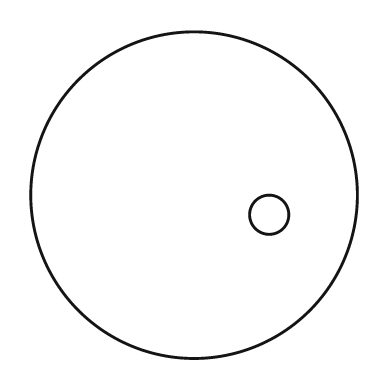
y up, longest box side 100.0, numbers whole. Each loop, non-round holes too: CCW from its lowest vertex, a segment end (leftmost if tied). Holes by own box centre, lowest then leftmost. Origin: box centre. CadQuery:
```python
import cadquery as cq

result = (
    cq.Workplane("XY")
    .moveTo(0.0, 0.0)
    .circle(50.0)
    .moveTo(23.0, -6.0)
    .circle(6.0)
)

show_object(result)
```